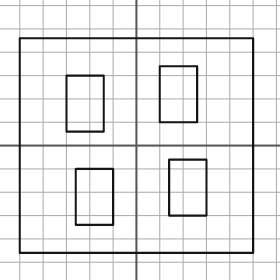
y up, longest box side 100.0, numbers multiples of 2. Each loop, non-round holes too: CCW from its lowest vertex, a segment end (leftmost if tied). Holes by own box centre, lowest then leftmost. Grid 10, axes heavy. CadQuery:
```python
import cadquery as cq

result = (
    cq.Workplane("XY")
    .moveTo(-50.0, -46.0)
    .lineTo(50.0, -46.0)
    .lineTo(50.0, 46.0)
    .lineTo(-50.0, 46.0)
    .close()
    .moveTo(-26.0, -34.0)
    .lineTo(-10.0, -34.0)
    .lineTo(-10.0, -10.0)
    .lineTo(-26.0, -10.0)
    .close()
    .moveTo(14.0, -30.0)
    .lineTo(30.0, -30.0)
    .lineTo(30.0, -6.0)
    .lineTo(14.0, -6.0)
    .close()
    .moveTo(-30.0, 6.0)
    .lineTo(-14.0, 6.0)
    .lineTo(-14.0, 30.0)
    .lineTo(-30.0, 30.0)
    .close()
    .moveTo(10.0, 10.0)
    .lineTo(26.0, 10.0)
    .lineTo(26.0, 34.0)
    .lineTo(10.0, 34.0)
    .close()
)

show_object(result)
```